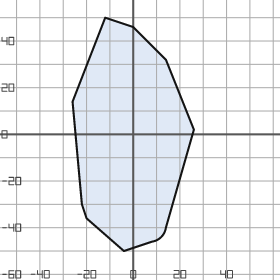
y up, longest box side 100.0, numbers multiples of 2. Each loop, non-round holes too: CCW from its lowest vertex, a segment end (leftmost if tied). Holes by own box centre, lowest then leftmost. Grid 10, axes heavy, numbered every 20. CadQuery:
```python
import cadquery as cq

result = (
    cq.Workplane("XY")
    .moveTo(-4.0, -50.0)
    .lineTo(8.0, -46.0)
    .threePointArc((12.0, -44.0), (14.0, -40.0))
    .lineTo(26.0, 2.0)
    .lineTo(14.0, 32.0)
    .lineTo(0.0, 46.0)
    .lineTo(-12.0, 50.0)
    .lineTo(-26.0, 14.0)
    .lineTo(-22.0, -30.0)
    .lineTo(-20.0, -36.0)
    .close()
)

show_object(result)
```